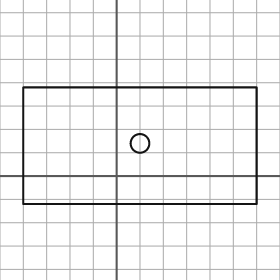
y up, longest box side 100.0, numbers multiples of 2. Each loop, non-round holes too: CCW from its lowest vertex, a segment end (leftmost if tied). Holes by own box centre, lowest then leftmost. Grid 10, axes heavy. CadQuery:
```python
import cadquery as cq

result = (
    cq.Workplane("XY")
    .moveTo(-40.0, -12.0)
    .lineTo(60.0, -12.0)
    .lineTo(60.0, 38.0)
    .lineTo(-40.0, 38.0)
    .close()
    .moveTo(10.0, 14.0)
    .circle(4.0)
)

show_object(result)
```